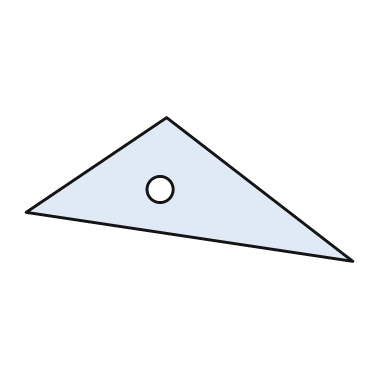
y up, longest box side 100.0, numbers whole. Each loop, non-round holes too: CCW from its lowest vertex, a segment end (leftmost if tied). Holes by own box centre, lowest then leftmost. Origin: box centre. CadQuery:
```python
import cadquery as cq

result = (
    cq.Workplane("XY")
    .moveTo(50.0, -22.0)
    .lineTo(-7.0, 22.0)
    .lineTo(-50.0, -7.0)
    .close()
    .moveTo(-9.0, 0.0)
    .circle(4.0)
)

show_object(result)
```